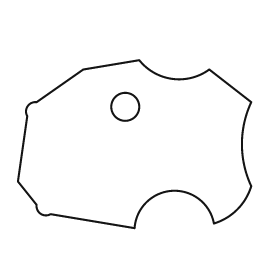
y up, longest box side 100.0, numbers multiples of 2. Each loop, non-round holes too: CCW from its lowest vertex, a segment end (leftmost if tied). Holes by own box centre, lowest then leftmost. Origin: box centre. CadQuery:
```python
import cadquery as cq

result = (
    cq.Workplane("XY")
    .moveTo(0.0, -36.0)
    .threePointArc((16.0, -20.0), (34.0, -34.0))
    .threePointArc((44.0, -28.0), (50.0, -18.0))
    .threePointArc((46.0, 0.0), (50.0, 18.0))
    .lineTo(32.0, 32.0)
    .threePointArc((16.0, 28.0), (2.0, 36.0))
    .lineTo(-22.0, 32.0)
    .lineTo(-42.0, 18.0)
    .threePointArc((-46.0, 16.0), (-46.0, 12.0))
    .lineTo(-50.0, -16.0)
    .lineTo(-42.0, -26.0)
    .threePointArc((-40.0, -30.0), (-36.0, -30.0))
    .close()
    .moveTo(-4.0, 16.0)
    .circle(6.0)
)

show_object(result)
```